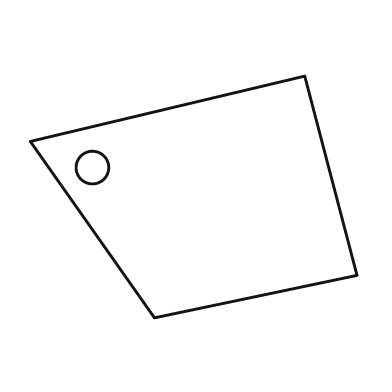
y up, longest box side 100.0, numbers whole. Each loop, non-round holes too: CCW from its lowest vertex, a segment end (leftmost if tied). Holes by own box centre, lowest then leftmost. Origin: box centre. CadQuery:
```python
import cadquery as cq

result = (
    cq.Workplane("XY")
    .moveTo(-12.0, -37.0)
    .lineTo(50.0, -24.0)
    .lineTo(34.0, 37.0)
    .lineTo(-50.0, 17.0)
    .close()
    .moveTo(-31.0, 9.0)
    .circle(5.0)
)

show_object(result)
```